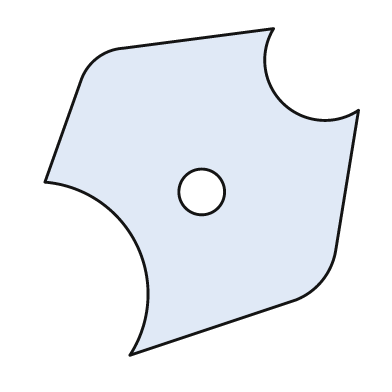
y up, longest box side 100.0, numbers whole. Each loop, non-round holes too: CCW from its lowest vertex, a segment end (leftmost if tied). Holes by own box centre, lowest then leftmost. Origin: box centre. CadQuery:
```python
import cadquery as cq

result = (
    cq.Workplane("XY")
    .moveTo(-22.0, -50.0)
    .lineTo(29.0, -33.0)
    .threePointArc((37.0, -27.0), (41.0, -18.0))
    .lineTo(48.0, 25.0)
    .threePointArc((25.0, 27.0), (22.0, 50.0))
    .lineTo(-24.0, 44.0)
    .threePointArc((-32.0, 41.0), (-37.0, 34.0))
    .lineTo(-48.0, 3.0)
    .threePointArc((-20.0, -16.0), (-22.0, -50.0))
    .close()
    .moveTo(0.0, 0.0)
    .circle(7.0)
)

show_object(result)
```